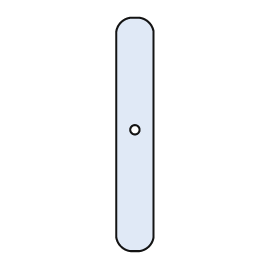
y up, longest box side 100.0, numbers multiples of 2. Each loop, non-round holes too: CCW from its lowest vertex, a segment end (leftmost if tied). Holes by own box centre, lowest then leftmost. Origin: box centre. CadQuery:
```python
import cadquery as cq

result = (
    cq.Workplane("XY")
    .moveTo(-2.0, -50.0)
    .lineTo(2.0, -50.0)
    .threePointArc((6.0, -48.0), (8.0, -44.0))
    .lineTo(8.0, 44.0)
    .threePointArc((6.0, 48.0), (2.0, 50.0))
    .lineTo(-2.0, 50.0)
    .threePointArc((-6.0, 48.0), (-8.0, 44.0))
    .lineTo(-8.0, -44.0)
    .threePointArc((-6.0, -48.0), (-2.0, -50.0))
    .close()
    .moveTo(0.0, 2.0)
    .circle(2.0)
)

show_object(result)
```